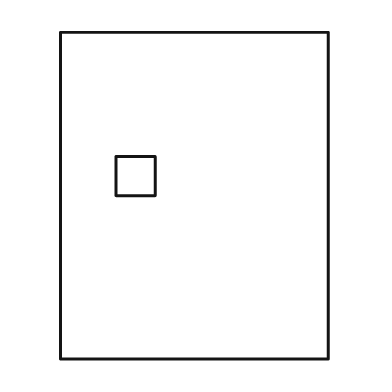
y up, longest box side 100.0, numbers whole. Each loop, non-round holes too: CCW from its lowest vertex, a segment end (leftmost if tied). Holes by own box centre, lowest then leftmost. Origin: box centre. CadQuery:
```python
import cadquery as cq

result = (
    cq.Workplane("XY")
    .moveTo(-41.0, -50.0)
    .lineTo(41.0, -50.0)
    .lineTo(41.0, 50.0)
    .lineTo(-41.0, 50.0)
    .close()
    .moveTo(-24.0, 0.0)
    .lineTo(-12.0, 0.0)
    .lineTo(-12.0, 12.0)
    .lineTo(-24.0, 12.0)
    .close()
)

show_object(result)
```